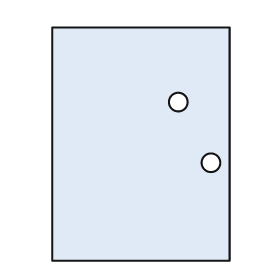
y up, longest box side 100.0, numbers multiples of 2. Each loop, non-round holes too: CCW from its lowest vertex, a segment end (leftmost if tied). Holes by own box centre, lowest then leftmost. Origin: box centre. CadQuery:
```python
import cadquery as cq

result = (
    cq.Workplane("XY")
    .moveTo(-38.0, -50.0)
    .lineTo(38.0, -50.0)
    .lineTo(38.0, 50.0)
    .lineTo(-38.0, 50.0)
    .close()
    .moveTo(30.0, -8.0)
    .circle(4.0)
    .moveTo(16.0, 18.0)
    .circle(4.0)
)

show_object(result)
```